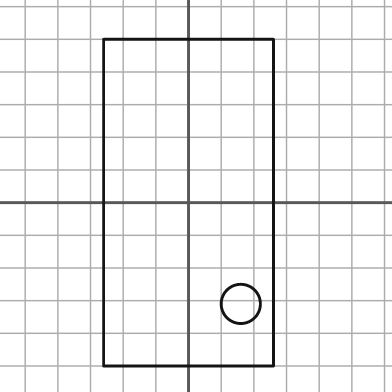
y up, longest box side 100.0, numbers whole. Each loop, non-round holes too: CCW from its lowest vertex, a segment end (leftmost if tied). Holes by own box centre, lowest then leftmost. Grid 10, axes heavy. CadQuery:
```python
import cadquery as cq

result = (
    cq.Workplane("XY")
    .moveTo(-26.0, -50.0)
    .lineTo(26.0, -50.0)
    .lineTo(26.0, 50.0)
    .lineTo(-26.0, 50.0)
    .close()
    .moveTo(16.0, -31.0)
    .circle(6.0)
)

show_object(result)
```